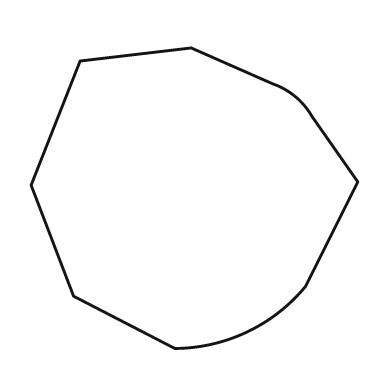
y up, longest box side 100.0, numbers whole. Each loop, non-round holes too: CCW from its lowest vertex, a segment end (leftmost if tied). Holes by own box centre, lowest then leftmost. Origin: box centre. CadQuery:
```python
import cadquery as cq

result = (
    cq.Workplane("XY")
    .moveTo(-6.0, -46.0)
    .threePointArc((16.0, -41.0), (34.0, -27.0))
    .lineTo(50.0, 5.0)
    .lineTo(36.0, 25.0)
    .threePointArc((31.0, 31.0), (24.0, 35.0))
    .lineTo(-1.0, 46.0)
    .lineTo(-35.0, 42.0)
    .lineTo(-50.0, 4.0)
    .lineTo(-37.0, -30.0)
    .close()
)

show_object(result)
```